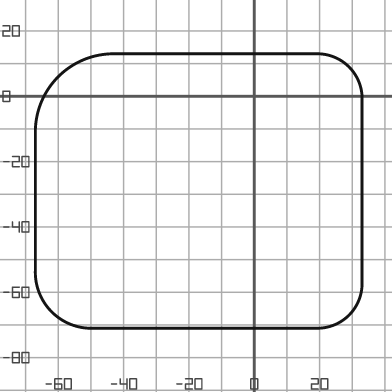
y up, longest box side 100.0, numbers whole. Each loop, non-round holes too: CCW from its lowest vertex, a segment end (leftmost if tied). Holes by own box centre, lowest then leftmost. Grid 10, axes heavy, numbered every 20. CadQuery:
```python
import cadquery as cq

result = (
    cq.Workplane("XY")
    .moveTo(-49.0, -71.0)
    .lineTo(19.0, -71.0)
    .threePointArc((29.0, -67.0), (33.0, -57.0))
    .lineTo(33.0, 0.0)
    .threePointArc((29.0, 9.0), (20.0, 13.0))
    .lineTo(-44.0, 13.0)
    .threePointArc((-60.0, 6.0), (-67.0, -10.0))
    .lineTo(-67.0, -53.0)
    .threePointArc((-62.0, -66.0), (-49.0, -71.0))
    .close()
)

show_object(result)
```